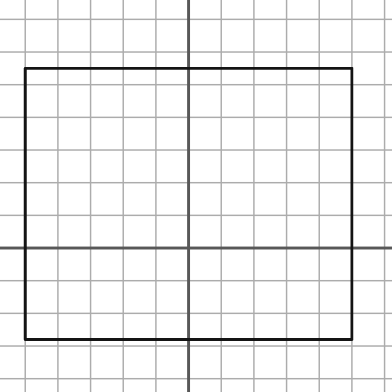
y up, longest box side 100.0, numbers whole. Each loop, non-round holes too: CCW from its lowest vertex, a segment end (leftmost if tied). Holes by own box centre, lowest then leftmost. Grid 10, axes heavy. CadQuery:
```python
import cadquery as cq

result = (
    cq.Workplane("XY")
    .moveTo(-50.0, -28.0)
    .lineTo(50.0, -28.0)
    .lineTo(50.0, 55.0)
    .lineTo(-50.0, 55.0)
    .close()
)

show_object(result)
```